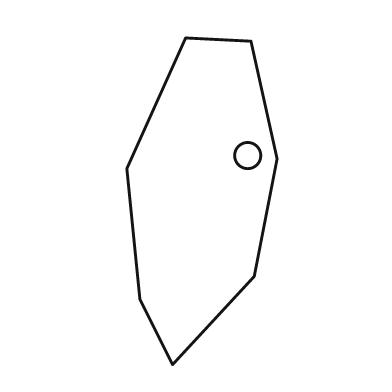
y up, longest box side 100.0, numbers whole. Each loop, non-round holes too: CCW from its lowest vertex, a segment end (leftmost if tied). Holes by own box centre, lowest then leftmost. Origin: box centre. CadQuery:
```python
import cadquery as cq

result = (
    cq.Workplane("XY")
    .moveTo(-9.0, -50.0)
    .lineTo(16.0, -23.0)
    .lineTo(23.0, 13.0)
    .lineTo(15.0, 49.0)
    .lineTo(-5.0, 50.0)
    .lineTo(-23.0, 10.0)
    .lineTo(-19.0, -30.0)
    .close()
    .moveTo(14.0, 14.0)
    .circle(4.0)
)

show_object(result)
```